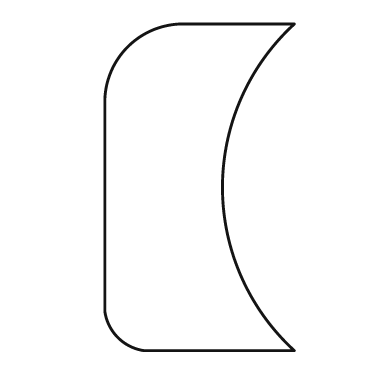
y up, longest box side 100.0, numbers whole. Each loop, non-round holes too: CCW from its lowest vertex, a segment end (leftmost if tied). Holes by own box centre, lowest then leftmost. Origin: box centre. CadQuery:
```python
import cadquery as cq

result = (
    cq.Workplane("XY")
    .moveTo(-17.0, -50.0)
    .lineTo(29.0, -50.0)
    .threePointArc((7.0, 0.0), (29.0, 50.0))
    .lineTo(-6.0, 50.0)
    .threePointArc((-22.0, 43.0), (-29.0, 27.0))
    .lineTo(-29.0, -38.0)
    .threePointArc((-25.0, -46.0), (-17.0, -50.0))
    .close()
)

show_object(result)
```